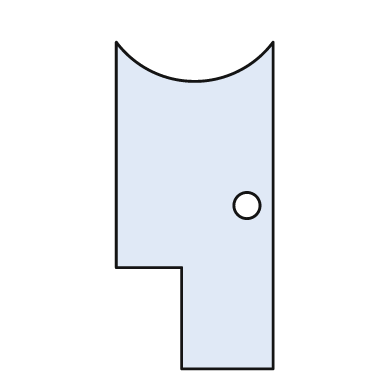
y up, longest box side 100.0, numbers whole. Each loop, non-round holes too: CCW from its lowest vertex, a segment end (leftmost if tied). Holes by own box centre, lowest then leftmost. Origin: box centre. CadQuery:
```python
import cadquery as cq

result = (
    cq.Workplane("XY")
    .moveTo(-4.0, -50.0)
    .lineTo(24.0, -50.0)
    .lineTo(24.0, 50.0)
    .threePointArc((0.0, 38.0), (-24.0, 50.0))
    .lineTo(-24.0, -19.0)
    .lineTo(-4.0, -19.0)
    .close()
    .moveTo(16.0, 0.0)
    .circle(4.0)
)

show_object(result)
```